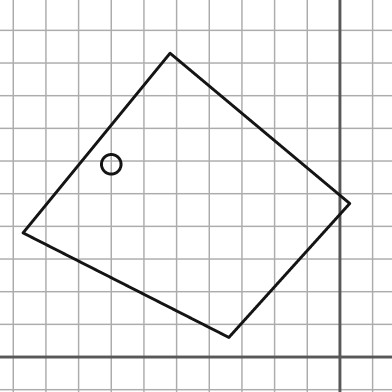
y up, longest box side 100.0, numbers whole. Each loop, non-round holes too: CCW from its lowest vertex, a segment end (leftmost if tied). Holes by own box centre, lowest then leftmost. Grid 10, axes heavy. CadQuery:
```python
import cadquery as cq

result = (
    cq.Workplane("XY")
    .moveTo(-34.0, 6.0)
    .lineTo(3.0, 47.0)
    .lineTo(-52.0, 93.0)
    .lineTo(-97.0, 38.0)
    .close()
    .moveTo(-70.0, 59.0)
    .circle(3.0)
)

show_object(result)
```